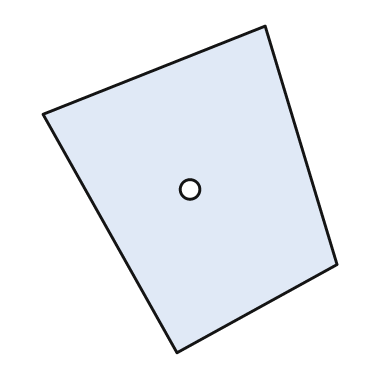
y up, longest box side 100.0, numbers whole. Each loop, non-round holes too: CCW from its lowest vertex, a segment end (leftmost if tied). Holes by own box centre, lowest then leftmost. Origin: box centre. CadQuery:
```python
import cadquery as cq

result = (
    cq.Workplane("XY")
    .moveTo(-4.0, -50.0)
    .lineTo(45.0, -23.0)
    .lineTo(23.0, 50.0)
    .lineTo(-45.0, 23.0)
    .close()
    .moveTo(0.0, 0.0)
    .circle(3.0)
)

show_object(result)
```